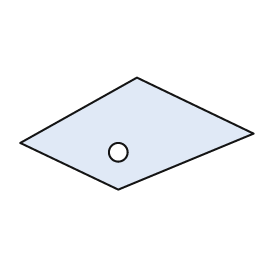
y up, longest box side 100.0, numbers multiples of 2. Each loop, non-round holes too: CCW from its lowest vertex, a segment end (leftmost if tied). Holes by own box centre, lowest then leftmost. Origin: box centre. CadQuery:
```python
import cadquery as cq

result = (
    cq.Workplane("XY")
    .moveTo(-8.0, -24.0)
    .lineTo(50.0, 0.0)
    .lineTo(0.0, 24.0)
    .lineTo(-50.0, -4.0)
    .close()
    .moveTo(-8.0, -8.0)
    .circle(4.0)
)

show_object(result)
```